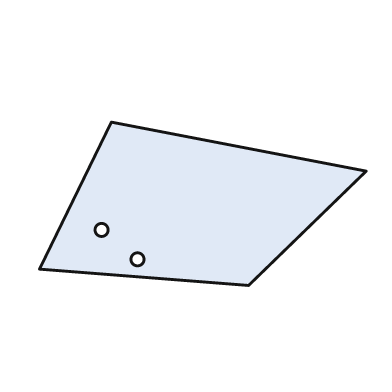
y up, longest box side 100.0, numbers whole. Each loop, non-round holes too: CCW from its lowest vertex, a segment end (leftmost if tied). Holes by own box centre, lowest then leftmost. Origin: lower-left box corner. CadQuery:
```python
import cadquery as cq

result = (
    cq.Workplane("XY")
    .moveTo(64.0, 0.0)
    .lineTo(100.0, 35.0)
    .lineTo(22.0, 50.0)
    .lineTo(0.0, 5.0)
    .close()
    .moveTo(30.0, 8.0)
    .circle(2.0)
    .moveTo(19.0, 17.0)
    .circle(2.0)
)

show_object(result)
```